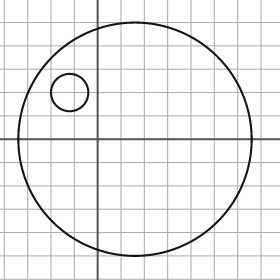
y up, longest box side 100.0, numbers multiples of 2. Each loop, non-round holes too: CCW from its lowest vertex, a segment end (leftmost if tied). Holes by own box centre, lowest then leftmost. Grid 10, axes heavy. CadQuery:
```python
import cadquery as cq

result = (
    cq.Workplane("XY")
    .moveTo(16.0, 0.0)
    .circle(50.0)
    .moveTo(-12.0, 20.0)
    .circle(8.0)
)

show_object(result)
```